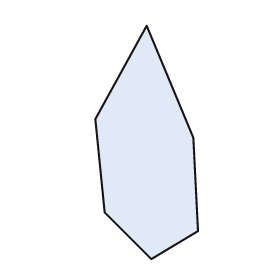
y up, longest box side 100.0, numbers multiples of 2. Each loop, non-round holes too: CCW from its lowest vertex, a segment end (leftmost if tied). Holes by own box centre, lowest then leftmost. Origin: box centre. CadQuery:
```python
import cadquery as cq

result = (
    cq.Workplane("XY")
    .moveTo(2.0, -50.0)
    .lineTo(22.0, -38.0)
    .lineTo(20.0, 2.0)
    .lineTo(0.0, 50.0)
    .lineTo(-22.0, 10.0)
    .lineTo(-18.0, -30.0)
    .close()
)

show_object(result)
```